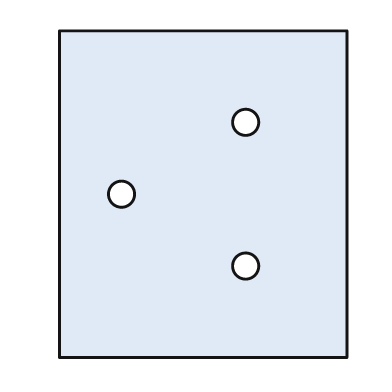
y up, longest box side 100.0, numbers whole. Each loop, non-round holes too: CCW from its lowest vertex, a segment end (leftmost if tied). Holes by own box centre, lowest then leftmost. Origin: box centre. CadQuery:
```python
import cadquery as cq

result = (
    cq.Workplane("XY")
    .moveTo(-44.0, -50.0)
    .lineTo(44.0, -50.0)
    .lineTo(44.0, 50.0)
    .lineTo(-44.0, 50.0)
    .close()
    .moveTo(13.0, -22.0)
    .circle(4.0)
    .moveTo(-25.0, 0.0)
    .circle(4.0)
    .moveTo(13.0, 22.0)
    .circle(4.0)
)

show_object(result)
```